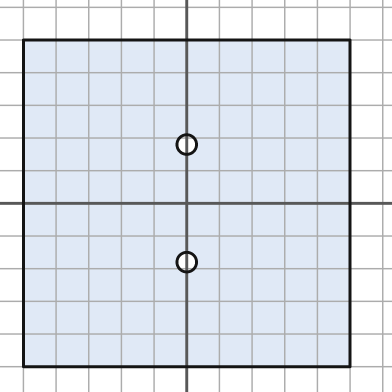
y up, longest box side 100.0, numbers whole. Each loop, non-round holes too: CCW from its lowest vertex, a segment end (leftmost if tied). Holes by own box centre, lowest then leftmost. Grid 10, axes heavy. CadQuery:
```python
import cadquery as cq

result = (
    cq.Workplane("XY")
    .moveTo(-50.0, -50.0)
    .lineTo(50.0, -50.0)
    .lineTo(50.0, 50.0)
    .lineTo(-50.0, 50.0)
    .close()
    .moveTo(0.0, -18.0)
    .circle(3.0)
    .moveTo(0.0, 18.0)
    .circle(3.0)
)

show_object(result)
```